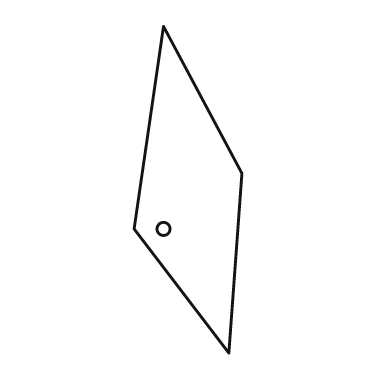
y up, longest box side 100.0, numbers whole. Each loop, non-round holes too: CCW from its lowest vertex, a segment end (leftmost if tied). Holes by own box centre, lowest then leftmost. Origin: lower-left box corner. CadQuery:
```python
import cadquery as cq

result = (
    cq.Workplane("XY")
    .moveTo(29.0, 0.0)
    .lineTo(33.0, 55.0)
    .lineTo(9.0, 100.0)
    .lineTo(0.0, 38.0)
    .close()
    .moveTo(9.0, 38.0)
    .circle(2.0)
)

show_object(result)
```